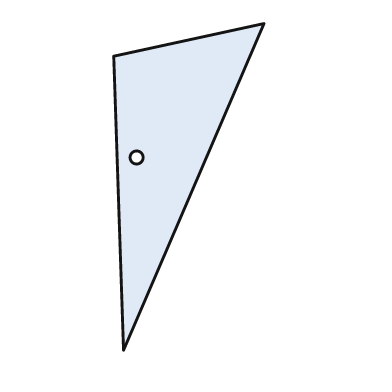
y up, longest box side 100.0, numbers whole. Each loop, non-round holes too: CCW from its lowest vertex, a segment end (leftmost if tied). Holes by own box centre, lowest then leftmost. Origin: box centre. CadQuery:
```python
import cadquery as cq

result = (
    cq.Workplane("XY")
    .moveTo(-20.0, -50.0)
    .lineTo(23.0, 50.0)
    .lineTo(-23.0, 40.0)
    .close()
    .moveTo(-16.0, 9.0)
    .circle(2.0)
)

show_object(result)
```